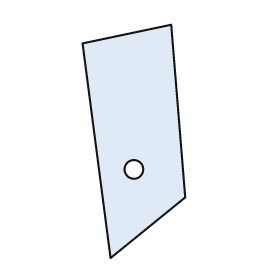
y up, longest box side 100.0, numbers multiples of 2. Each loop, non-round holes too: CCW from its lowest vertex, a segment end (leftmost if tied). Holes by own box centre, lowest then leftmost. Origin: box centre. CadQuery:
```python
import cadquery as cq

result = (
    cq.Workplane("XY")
    .moveTo(-10.0, -50.0)
    .lineTo(22.0, -24.0)
    .lineTo(16.0, 50.0)
    .lineTo(-22.0, 42.0)
    .close()
    .moveTo(0.0, -12.0)
    .circle(4.0)
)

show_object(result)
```